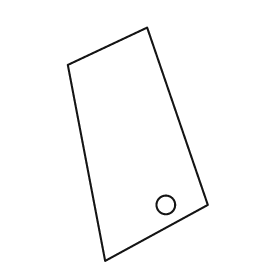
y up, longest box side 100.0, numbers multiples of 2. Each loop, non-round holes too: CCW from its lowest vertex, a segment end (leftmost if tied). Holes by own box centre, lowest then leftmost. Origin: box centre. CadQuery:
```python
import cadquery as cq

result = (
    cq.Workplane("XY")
    .moveTo(-14.0, -50.0)
    .lineTo(30.0, -26.0)
    .lineTo(4.0, 50.0)
    .lineTo(-30.0, 34.0)
    .close()
    .moveTo(12.0, -26.0)
    .circle(4.0)
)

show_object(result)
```